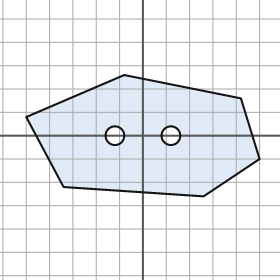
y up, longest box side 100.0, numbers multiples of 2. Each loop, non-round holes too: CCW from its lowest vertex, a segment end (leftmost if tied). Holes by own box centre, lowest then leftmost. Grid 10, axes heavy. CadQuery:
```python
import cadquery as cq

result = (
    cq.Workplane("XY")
    .moveTo(26.0, -26.0)
    .lineTo(50.0, -10.0)
    .lineTo(42.0, 16.0)
    .lineTo(-8.0, 26.0)
    .lineTo(-50.0, 8.0)
    .lineTo(-34.0, -22.0)
    .close()
    .moveTo(-12.0, 0.0)
    .circle(4.0)
    .moveTo(12.0, 0.0)
    .circle(4.0)
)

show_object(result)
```